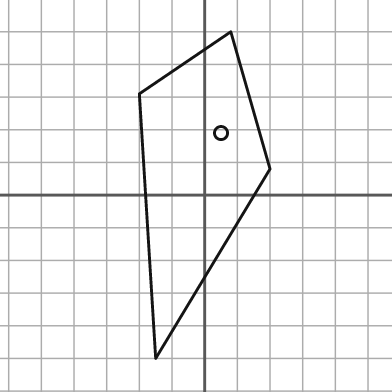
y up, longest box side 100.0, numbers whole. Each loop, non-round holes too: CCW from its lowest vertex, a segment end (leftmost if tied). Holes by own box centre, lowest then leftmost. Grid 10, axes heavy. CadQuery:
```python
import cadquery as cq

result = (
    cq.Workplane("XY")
    .moveTo(-15.0, -50.0)
    .lineTo(20.0, 8.0)
    .lineTo(8.0, 50.0)
    .lineTo(-20.0, 31.0)
    .close()
    .moveTo(5.0, 19.0)
    .circle(2.0)
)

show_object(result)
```